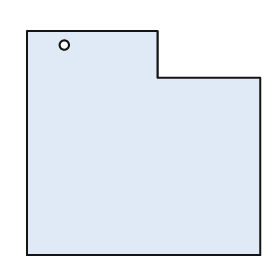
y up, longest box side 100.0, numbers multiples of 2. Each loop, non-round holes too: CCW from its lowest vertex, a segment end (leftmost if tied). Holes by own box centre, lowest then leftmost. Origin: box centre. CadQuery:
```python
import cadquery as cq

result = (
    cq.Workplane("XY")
    .moveTo(-50.0, -48.0)
    .lineTo(50.0, -48.0)
    .lineTo(50.0, 28.0)
    .lineTo(6.0, 28.0)
    .lineTo(6.0, 48.0)
    .lineTo(-50.0, 48.0)
    .close()
    .moveTo(-34.0, 42.0)
    .circle(2.0)
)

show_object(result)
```